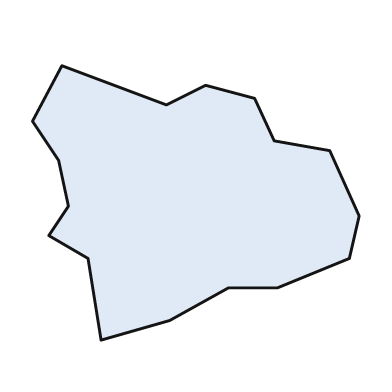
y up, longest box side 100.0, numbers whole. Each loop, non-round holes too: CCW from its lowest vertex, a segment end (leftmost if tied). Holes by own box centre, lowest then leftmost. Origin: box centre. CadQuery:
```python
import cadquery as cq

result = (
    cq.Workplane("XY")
    .moveTo(-29.0, -42.0)
    .lineTo(-8.0, -36.0)
    .lineTo(10.0, -26.0)
    .lineTo(25.0, -26.0)
    .lineTo(47.0, -17.0)
    .lineTo(50.0, -4.0)
    .lineTo(41.0, 16.0)
    .lineTo(24.0, 19.0)
    .lineTo(18.0, 32.0)
    .lineTo(3.0, 36.0)
    .lineTo(-9.0, 30.0)
    .lineTo(-41.0, 42.0)
    .lineTo(-50.0, 25.0)
    .lineTo(-42.0, 13.0)
    .lineTo(-39.0, -1.0)
    .lineTo(-45.0, -10.0)
    .lineTo(-33.0, -17.0)
    .close()
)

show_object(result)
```